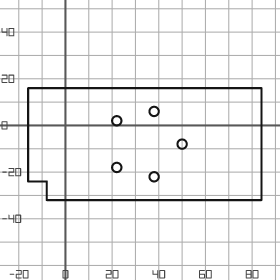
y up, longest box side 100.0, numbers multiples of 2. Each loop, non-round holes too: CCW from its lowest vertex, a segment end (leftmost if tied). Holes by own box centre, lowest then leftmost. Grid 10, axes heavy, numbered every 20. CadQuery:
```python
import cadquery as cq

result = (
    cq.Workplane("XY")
    .moveTo(-8.0, -32.0)
    .lineTo(84.0, -32.0)
    .lineTo(84.0, 16.0)
    .lineTo(-16.0, 16.0)
    .lineTo(-16.0, -24.0)
    .lineTo(-8.0, -24.0)
    .close()
    .moveTo(38.0, -22.0)
    .circle(2.0)
    .moveTo(22.0, -18.0)
    .circle(2.0)
    .moveTo(50.0, -8.0)
    .circle(2.0)
    .moveTo(22.0, 2.0)
    .circle(2.0)
    .moveTo(38.0, 6.0)
    .circle(2.0)
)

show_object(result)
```